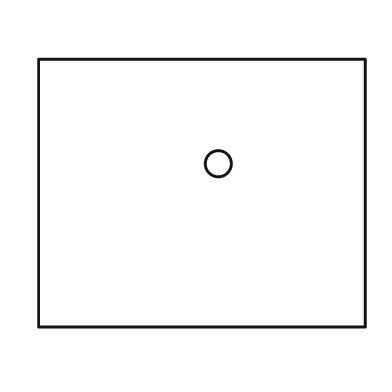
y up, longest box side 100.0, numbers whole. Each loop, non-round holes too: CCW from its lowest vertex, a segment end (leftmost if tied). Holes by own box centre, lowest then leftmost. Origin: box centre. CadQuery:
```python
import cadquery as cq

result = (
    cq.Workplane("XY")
    .moveTo(-50.0, -41.0)
    .lineTo(50.0, -41.0)
    .lineTo(50.0, 41.0)
    .lineTo(-50.0, 41.0)
    .close()
    .moveTo(5.0, 9.0)
    .circle(4.0)
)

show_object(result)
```